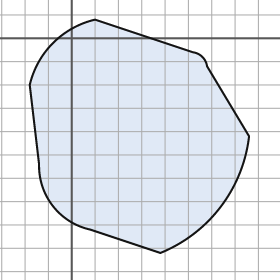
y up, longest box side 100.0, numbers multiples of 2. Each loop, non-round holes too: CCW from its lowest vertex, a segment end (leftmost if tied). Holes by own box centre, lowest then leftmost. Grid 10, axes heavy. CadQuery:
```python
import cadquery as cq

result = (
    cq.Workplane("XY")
    .moveTo(38.0, -92.0)
    .threePointArc((64.0, -72.0), (76.0, -42.0))
    .lineTo(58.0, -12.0)
    .threePointArc((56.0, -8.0), (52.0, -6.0))
    .lineTo(10.0, 8.0)
    .threePointArc((-8.0, -2.0), (-18.0, -20.0))
    .lineTo(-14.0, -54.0)
    .threePointArc((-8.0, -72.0), (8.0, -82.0))
    .close()
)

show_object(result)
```